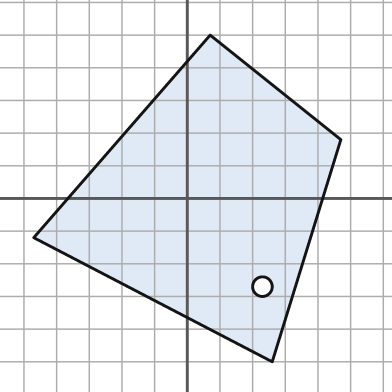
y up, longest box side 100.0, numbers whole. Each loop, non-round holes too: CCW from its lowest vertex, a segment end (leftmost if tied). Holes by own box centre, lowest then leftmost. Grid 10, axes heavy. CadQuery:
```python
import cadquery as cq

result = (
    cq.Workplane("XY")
    .moveTo(26.0, -50.0)
    .lineTo(47.0, 18.0)
    .lineTo(7.0, 50.0)
    .lineTo(-47.0, -12.0)
    .close()
    .moveTo(23.0, -27.0)
    .circle(3.0)
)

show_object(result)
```